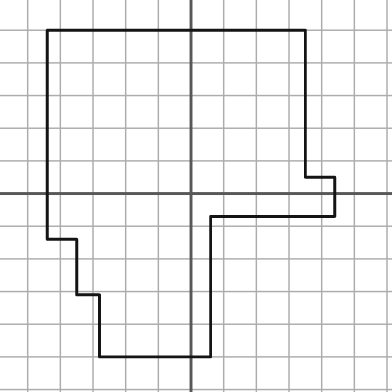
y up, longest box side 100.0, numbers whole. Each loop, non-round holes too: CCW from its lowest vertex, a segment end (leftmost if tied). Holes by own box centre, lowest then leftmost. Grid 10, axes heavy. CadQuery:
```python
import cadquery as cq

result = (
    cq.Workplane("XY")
    .moveTo(-28.0, -50.0)
    .lineTo(6.0, -50.0)
    .lineTo(6.0, -7.0)
    .lineTo(44.0, -7.0)
    .lineTo(44.0, 5.0)
    .lineTo(35.0, 5.0)
    .lineTo(35.0, 50.0)
    .lineTo(-44.0, 50.0)
    .lineTo(-44.0, -14.0)
    .lineTo(-35.0, -14.0)
    .lineTo(-35.0, -31.0)
    .lineTo(-28.0, -31.0)
    .close()
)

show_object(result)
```